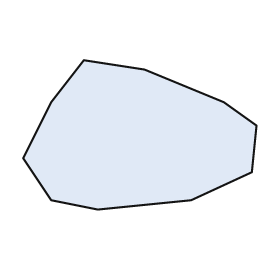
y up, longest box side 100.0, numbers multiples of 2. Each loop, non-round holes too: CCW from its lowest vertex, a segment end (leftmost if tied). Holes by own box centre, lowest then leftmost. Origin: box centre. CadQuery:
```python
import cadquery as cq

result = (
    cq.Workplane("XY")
    .moveTo(-18.0, -32.0)
    .lineTo(22.0, -28.0)
    .lineTo(48.0, -16.0)
    .lineTo(50.0, 4.0)
    .lineTo(36.0, 14.0)
    .lineTo(2.0, 28.0)
    .lineTo(-24.0, 32.0)
    .lineTo(-38.0, 14.0)
    .lineTo(-50.0, -10.0)
    .lineTo(-38.0, -28.0)
    .close()
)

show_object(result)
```